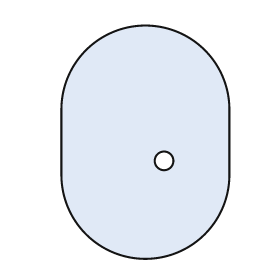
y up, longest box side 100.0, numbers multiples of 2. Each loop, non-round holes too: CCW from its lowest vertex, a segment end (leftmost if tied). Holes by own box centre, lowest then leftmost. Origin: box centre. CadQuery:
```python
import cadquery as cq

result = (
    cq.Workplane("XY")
    .moveTo(-36.0, -14.0)
    .threePointArc((0.0, -50.0), (36.0, -14.0))
    .lineTo(36.0, 14.0)
    .threePointArc((0.0, 50.0), (-36.0, 14.0))
    .close()
    .moveTo(8.0, -8.0)
    .circle(4.0)
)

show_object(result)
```